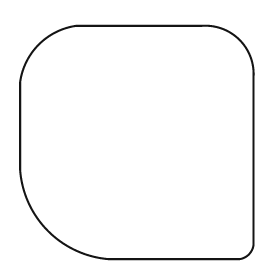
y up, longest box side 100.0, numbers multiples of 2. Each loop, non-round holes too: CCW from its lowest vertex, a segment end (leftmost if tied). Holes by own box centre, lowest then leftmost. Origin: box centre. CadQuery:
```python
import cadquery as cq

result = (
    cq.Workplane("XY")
    .moveTo(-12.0, -50.0)
    .lineTo(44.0, -50.0)
    .threePointArc((48.0, -48.0), (50.0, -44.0))
    .lineTo(50.0, 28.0)
    .threePointArc((44.0, 44.0), (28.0, 50.0))
    .lineTo(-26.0, 50.0)
    .threePointArc((-42.0, 42.0), (-50.0, 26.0))
    .lineTo(-50.0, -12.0)
    .threePointArc((-38.0, -38.0), (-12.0, -50.0))
    .close()
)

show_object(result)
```